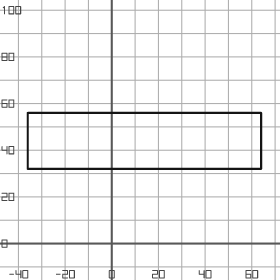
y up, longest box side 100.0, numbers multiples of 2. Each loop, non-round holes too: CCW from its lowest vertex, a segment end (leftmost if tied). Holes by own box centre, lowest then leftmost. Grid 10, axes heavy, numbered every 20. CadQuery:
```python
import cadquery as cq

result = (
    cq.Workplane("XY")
    .moveTo(-36.0, 32.0)
    .lineTo(64.0, 32.0)
    .lineTo(64.0, 56.0)
    .lineTo(-36.0, 56.0)
    .close()
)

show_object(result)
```